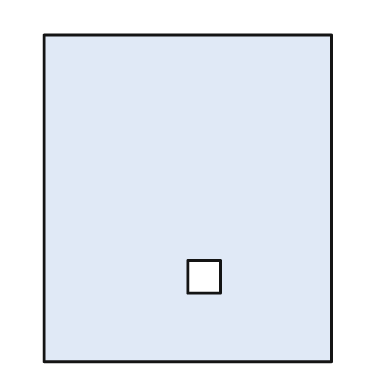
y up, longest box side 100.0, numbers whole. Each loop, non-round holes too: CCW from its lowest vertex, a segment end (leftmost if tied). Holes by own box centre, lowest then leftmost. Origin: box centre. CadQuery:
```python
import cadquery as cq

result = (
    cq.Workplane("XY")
    .moveTo(-44.0, -50.0)
    .lineTo(44.0, -50.0)
    .lineTo(44.0, 50.0)
    .lineTo(-44.0, 50.0)
    .close()
    .moveTo(0.0, -29.0)
    .lineTo(10.0, -29.0)
    .lineTo(10.0, -19.0)
    .lineTo(0.0, -19.0)
    .close()
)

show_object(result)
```